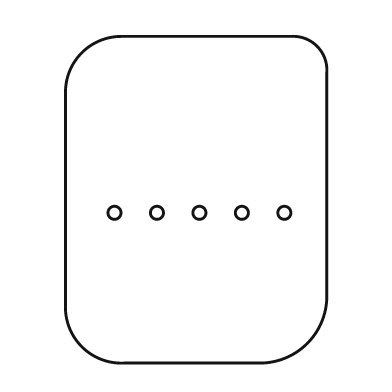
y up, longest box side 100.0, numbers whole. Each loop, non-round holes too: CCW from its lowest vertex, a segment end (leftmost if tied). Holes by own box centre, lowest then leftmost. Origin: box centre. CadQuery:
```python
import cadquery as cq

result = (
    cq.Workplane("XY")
    .moveTo(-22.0, -50.0)
    .lineTo(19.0, -50.0)
    .threePointArc((34.0, -44.0), (40.0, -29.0))
    .lineTo(40.0, 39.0)
    .threePointArc((37.0, 47.0), (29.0, 50.0))
    .lineTo(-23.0, 50.0)
    .threePointArc((-35.0, 45.0), (-40.0, 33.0))
    .lineTo(-40.0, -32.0)
    .threePointArc((-35.0, -45.0), (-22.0, -50.0))
    .close()
    .moveTo(-25.0, -4.0)
    .circle(2.0)
    .moveTo(-12.0, -4.0)
    .circle(2.0)
    .moveTo(1.0, -4.0)
    .circle(2.0)
    .moveTo(14.0, -4.0)
    .circle(2.0)
    .moveTo(27.0, -4.0)
    .circle(2.0)
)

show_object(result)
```